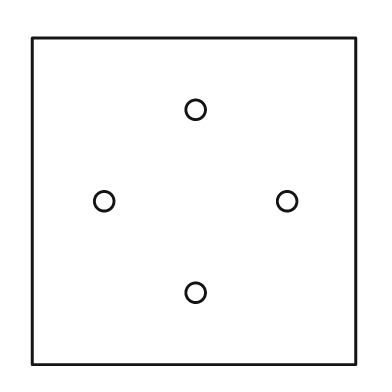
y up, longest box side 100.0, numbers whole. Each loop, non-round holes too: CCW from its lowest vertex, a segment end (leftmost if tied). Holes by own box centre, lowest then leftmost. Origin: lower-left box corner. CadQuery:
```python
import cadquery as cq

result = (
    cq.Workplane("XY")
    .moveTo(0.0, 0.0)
    .lineTo(99.0, 0.0)
    .lineTo(99.0, 100.0)
    .lineTo(0.0, 100.0)
    .close()
    .moveTo(50.0, 22.0)
    .circle(3.0)
    .moveTo(22.0, 50.0)
    .circle(3.0)
    .moveTo(78.0, 50.0)
    .circle(3.0)
    .moveTo(50.0, 78.0)
    .circle(3.0)
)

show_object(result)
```